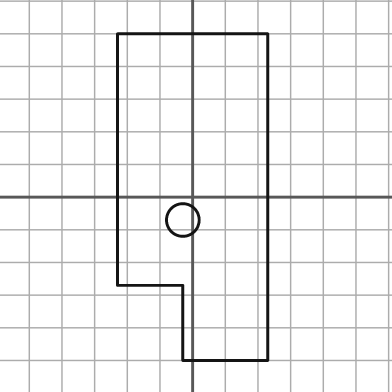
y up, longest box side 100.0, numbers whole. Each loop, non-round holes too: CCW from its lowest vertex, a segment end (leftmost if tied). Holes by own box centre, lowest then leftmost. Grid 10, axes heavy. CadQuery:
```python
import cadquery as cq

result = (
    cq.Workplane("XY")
    .moveTo(-3.0, -50.0)
    .lineTo(23.0, -50.0)
    .lineTo(23.0, 50.0)
    .lineTo(-23.0, 50.0)
    .lineTo(-23.0, -27.0)
    .lineTo(-3.0, -27.0)
    .close()
    .moveTo(-3.0, -7.0)
    .circle(5.0)
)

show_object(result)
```